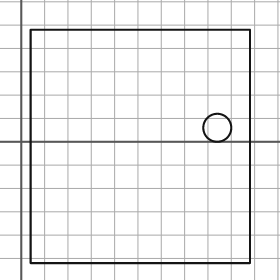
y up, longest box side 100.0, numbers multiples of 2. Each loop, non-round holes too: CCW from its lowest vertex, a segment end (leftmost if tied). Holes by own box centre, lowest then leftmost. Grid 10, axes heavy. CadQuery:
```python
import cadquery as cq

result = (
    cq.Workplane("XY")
    .moveTo(4.0, -52.0)
    .lineTo(98.0, -52.0)
    .lineTo(98.0, 48.0)
    .lineTo(4.0, 48.0)
    .close()
    .moveTo(84.0, 6.0)
    .circle(6.0)
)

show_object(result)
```